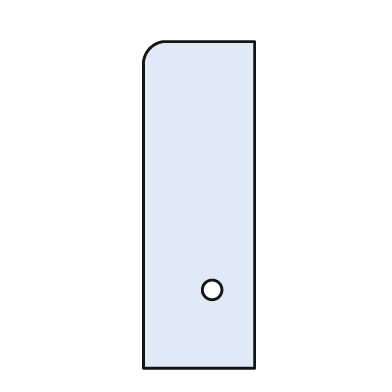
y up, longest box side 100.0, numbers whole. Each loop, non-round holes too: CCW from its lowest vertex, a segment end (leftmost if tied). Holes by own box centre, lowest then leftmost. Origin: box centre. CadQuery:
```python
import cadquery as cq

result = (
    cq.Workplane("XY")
    .moveTo(-17.0, -50.0)
    .lineTo(17.0, -50.0)
    .lineTo(17.0, 50.0)
    .lineTo(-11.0, 50.0)
    .threePointArc((-15.0, 48.0), (-17.0, 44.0))
    .close()
    .moveTo(4.0, -26.0)
    .circle(3.0)
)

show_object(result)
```